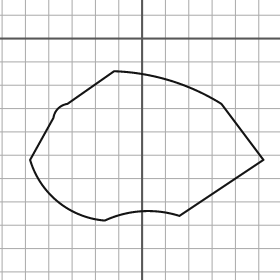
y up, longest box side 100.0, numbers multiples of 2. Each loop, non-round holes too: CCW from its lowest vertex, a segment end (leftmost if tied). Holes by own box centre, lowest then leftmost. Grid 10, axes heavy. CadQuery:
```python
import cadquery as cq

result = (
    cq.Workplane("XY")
    .moveTo(-16.0, -78.0)
    .threePointArc((0.0, -74.0), (16.0, -76.0))
    .lineTo(52.0, -52.0)
    .lineTo(34.0, -28.0)
    .threePointArc((12.0, -18.0), (-12.0, -14.0))
    .lineTo(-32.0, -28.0)
    .threePointArc((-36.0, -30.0), (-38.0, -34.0))
    .lineTo(-48.0, -52.0)
    .threePointArc((-36.0, -70.0), (-16.0, -78.0))
    .close()
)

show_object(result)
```